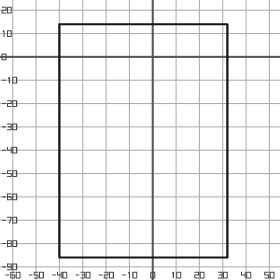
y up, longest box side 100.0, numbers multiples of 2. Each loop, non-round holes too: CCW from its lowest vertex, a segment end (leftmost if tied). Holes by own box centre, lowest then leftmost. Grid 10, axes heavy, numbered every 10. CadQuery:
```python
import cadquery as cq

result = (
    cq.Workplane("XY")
    .moveTo(-40.0, -86.0)
    .lineTo(32.0, -86.0)
    .lineTo(32.0, 14.0)
    .lineTo(-40.0, 14.0)
    .close()
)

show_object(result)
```